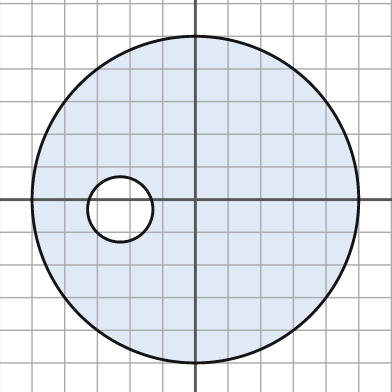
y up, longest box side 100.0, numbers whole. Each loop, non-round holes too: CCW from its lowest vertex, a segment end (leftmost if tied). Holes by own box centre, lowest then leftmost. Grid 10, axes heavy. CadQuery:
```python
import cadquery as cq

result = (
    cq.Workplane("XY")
    .moveTo(0.0, 0.0)
    .circle(50.0)
    .moveTo(-23.0, -3.0)
    .circle(10.0)
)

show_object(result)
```